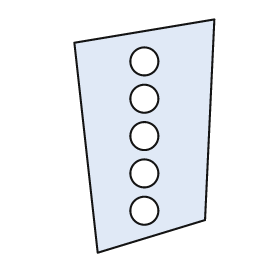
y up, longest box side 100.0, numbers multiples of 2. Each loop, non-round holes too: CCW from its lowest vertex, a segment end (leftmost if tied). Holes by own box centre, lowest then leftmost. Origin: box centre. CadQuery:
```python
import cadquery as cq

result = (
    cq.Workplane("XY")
    .moveTo(-20.0, -50.0)
    .lineTo(26.0, -36.0)
    .lineTo(30.0, 50.0)
    .lineTo(-30.0, 40.0)
    .close()
    .moveTo(0.0, -32.0)
    .circle(6.0)
    .moveTo(0.0, -16.0)
    .circle(6.0)
    .moveTo(0.0, 0.0)
    .circle(6.0)
    .moveTo(0.0, 16.0)
    .circle(6.0)
    .moveTo(0.0, 32.0)
    .circle(6.0)
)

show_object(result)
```